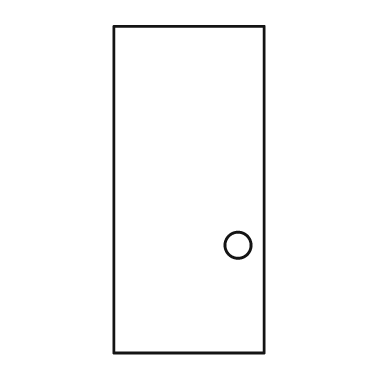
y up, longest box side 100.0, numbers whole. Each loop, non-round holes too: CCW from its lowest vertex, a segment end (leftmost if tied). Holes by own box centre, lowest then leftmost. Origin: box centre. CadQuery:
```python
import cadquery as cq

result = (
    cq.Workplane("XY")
    .moveTo(-23.0, -50.0)
    .lineTo(23.0, -50.0)
    .lineTo(23.0, 50.0)
    .lineTo(-23.0, 50.0)
    .close()
    .moveTo(15.0, -17.0)
    .circle(4.0)
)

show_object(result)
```